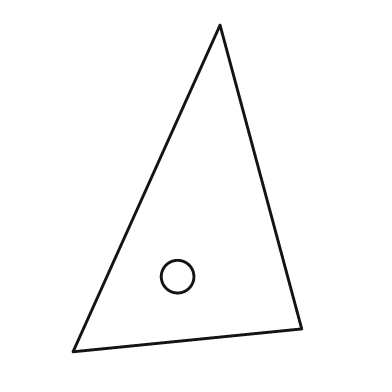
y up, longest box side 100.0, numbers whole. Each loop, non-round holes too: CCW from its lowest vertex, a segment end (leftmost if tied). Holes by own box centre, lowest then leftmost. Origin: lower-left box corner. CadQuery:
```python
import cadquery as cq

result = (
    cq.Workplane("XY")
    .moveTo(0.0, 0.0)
    .lineTo(70.0, 7.0)
    .lineTo(45.0, 100.0)
    .close()
    .moveTo(32.0, 23.0)
    .circle(5.0)
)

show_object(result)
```